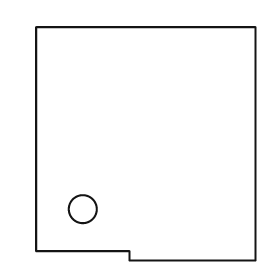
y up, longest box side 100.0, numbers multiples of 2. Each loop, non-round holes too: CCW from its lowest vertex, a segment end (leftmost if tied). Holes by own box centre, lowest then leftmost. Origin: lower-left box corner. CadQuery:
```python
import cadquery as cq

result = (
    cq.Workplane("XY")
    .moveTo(40.0, 0.0)
    .lineTo(94.0, 0.0)
    .lineTo(94.0, 100.0)
    .lineTo(0.0, 100.0)
    .lineTo(0.0, 4.0)
    .lineTo(40.0, 4.0)
    .close()
    .moveTo(20.0, 22.0)
    .circle(6.0)
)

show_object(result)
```